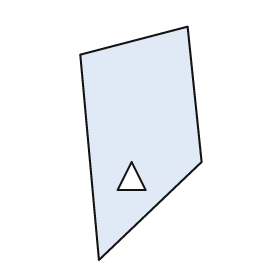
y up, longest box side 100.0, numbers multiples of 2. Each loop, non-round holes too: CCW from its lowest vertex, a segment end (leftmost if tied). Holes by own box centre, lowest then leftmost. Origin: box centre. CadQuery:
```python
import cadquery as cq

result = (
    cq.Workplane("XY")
    .moveTo(-18.0, -50.0)
    .lineTo(26.0, -8.0)
    .lineTo(20.0, 50.0)
    .lineTo(-26.0, 38.0)
    .close()
    .moveTo(-10.0, -20.0)
    .lineTo(2.0, -20.0)
    .lineTo(-4.0, -8.0)
    .close()
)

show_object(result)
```